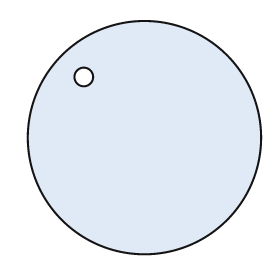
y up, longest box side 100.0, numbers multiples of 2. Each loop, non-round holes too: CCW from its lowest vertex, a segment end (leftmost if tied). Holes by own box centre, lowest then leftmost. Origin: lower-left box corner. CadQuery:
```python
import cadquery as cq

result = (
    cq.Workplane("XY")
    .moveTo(50.0, 50.0)
    .circle(50.0)
    .moveTo(24.0, 76.0)
    .circle(4.0)
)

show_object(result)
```